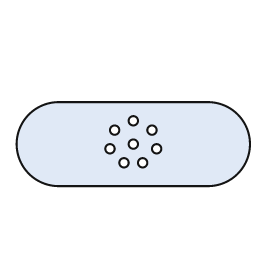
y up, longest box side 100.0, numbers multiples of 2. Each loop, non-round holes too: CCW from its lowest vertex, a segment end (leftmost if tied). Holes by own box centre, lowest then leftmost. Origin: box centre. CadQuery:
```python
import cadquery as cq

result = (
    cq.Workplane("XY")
    .moveTo(-32.0, -18.0)
    .lineTo(32.0, -18.0)
    .threePointArc((50.0, 0.0), (32.0, 18.0))
    .lineTo(-32.0, 18.0)
    .threePointArc((-50.0, 0.0), (-32.0, -18.0))
    .close()
    .moveTo(-4.0, -8.0)
    .circle(2.0)
    .moveTo(4.0, -8.0)
    .circle(2.0)
    .moveTo(-10.0, -2.0)
    .circle(2.0)
    .moveTo(10.0, -2.0)
    .circle(2.0)
    .moveTo(0.0, 0.0)
    .circle(2.0)
    .moveTo(-8.0, 6.0)
    .circle(2.0)
    .moveTo(8.0, 6.0)
    .circle(2.0)
    .moveTo(0.0, 10.0)
    .circle(2.0)
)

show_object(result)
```